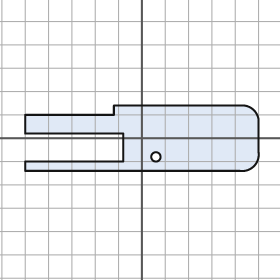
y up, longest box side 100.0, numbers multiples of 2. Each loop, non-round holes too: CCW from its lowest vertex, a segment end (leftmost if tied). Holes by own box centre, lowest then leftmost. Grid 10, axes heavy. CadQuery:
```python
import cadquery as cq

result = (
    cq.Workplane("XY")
    .moveTo(-50.0, -14.0)
    .lineTo(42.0, -14.0)
    .threePointArc((48.0, -12.0), (50.0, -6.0))
    .lineTo(50.0, 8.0)
    .threePointArc((48.0, 12.0), (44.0, 14.0))
    .lineTo(-12.0, 14.0)
    .lineTo(-12.0, 10.0)
    .lineTo(-50.0, 10.0)
    .lineTo(-50.0, 2.0)
    .lineTo(-8.0, 2.0)
    .lineTo(-8.0, -10.0)
    .lineTo(-50.0, -10.0)
    .close()
    .moveTo(6.0, -8.0)
    .circle(2.0)
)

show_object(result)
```